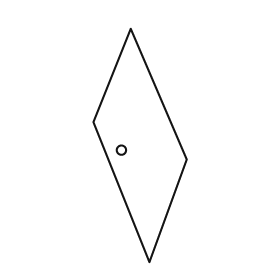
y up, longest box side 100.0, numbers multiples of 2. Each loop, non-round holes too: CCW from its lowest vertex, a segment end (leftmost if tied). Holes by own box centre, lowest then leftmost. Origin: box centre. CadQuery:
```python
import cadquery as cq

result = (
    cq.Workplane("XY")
    .moveTo(4.0, -50.0)
    .lineTo(20.0, -6.0)
    .lineTo(-4.0, 50.0)
    .lineTo(-20.0, 10.0)
    .close()
    .moveTo(-8.0, -2.0)
    .circle(2.0)
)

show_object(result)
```